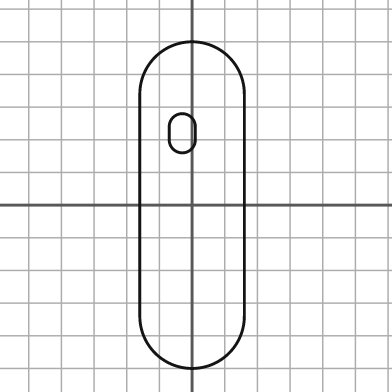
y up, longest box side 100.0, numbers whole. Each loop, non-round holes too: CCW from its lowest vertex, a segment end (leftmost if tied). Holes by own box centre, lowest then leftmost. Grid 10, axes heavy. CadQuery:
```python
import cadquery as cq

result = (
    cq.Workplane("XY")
    .moveTo(-16.0, -34.0)
    .threePointArc((0.0, -50.0), (16.0, -34.0))
    .lineTo(16.0, 34.0)
    .threePointArc((0.0, 50.0), (-16.0, 34.0))
    .close()
    .moveTo(-7.0, 20.0)
    .threePointArc((-3.0, 16.0), (1.0, 20.0))
    .lineTo(1.0, 24.0)
    .threePointArc((-3.0, 28.0), (-7.0, 24.0))
    .close()
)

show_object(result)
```